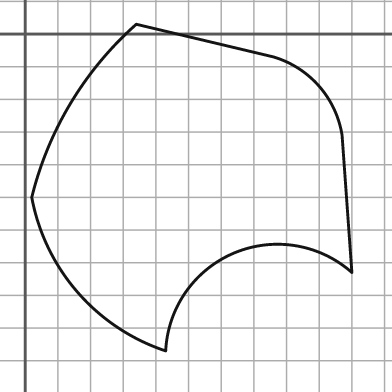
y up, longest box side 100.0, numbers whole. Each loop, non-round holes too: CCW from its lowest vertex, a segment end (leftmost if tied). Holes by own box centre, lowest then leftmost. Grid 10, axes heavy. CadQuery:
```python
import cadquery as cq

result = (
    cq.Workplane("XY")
    .moveTo(43.0, -97.0)
    .threePointArc((64.0, -67.0), (100.0, -73.0))
    .lineTo(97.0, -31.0)
    .threePointArc((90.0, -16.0), (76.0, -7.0))
    .lineTo(34.0, 3.0)
    .threePointArc((14.0, -21.0), (2.0, -50.0))
    .threePointArc((16.0, -79.0), (43.0, -97.0))
    .close()
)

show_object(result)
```